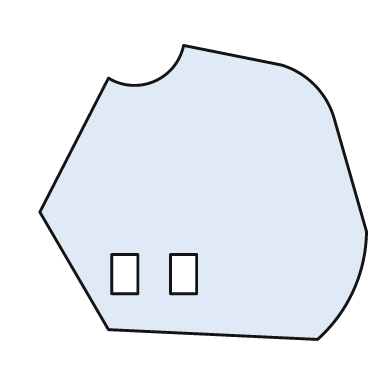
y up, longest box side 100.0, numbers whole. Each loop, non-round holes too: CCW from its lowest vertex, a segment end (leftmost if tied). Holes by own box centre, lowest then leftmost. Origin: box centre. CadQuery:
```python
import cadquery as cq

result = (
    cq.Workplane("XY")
    .moveTo(35.0, -45.0)
    .threePointArc((46.0, -30.0), (50.0, -12.0))
    .lineTo(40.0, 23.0)
    .threePointArc((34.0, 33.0), (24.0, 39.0))
    .lineTo(-6.0, 45.0)
    .threePointArc((-15.0, 34.0), (-29.0, 35.0))
    .lineTo(-50.0, -6.0)
    .lineTo(-29.0, -42.0)
    .close()
    .moveTo(-28.0, -31.0)
    .lineTo(-20.0, -31.0)
    .lineTo(-20.0, -19.0)
    .lineTo(-28.0, -19.0)
    .close()
    .moveTo(-10.0, -31.0)
    .lineTo(-2.0, -31.0)
    .lineTo(-2.0, -19.0)
    .lineTo(-10.0, -19.0)
    .close()
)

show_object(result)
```